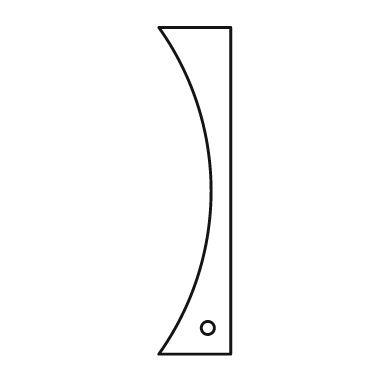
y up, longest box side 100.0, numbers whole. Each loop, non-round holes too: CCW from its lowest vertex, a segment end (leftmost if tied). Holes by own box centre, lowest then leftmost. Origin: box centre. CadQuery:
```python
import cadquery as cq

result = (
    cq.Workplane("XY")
    .moveTo(-11.0, -50.0)
    .lineTo(11.0, -50.0)
    .lineTo(11.0, 50.0)
    .lineTo(-11.0, 50.0)
    .threePointArc((5.0, 0.0), (-11.0, -50.0))
    .close()
    .moveTo(4.0, -42.0)
    .circle(2.0)
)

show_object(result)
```